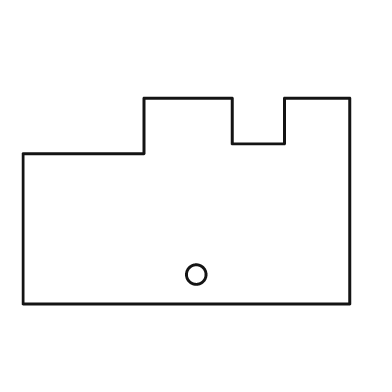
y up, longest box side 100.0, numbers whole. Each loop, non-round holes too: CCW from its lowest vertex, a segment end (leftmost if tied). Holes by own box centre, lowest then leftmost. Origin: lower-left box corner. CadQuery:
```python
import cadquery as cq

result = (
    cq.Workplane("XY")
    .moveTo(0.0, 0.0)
    .lineTo(100.0, 0.0)
    .lineTo(100.0, 63.0)
    .lineTo(80.0, 63.0)
    .lineTo(80.0, 49.0)
    .lineTo(64.0, 49.0)
    .lineTo(64.0, 63.0)
    .lineTo(37.0, 63.0)
    .lineTo(37.0, 46.0)
    .lineTo(0.0, 46.0)
    .close()
    .moveTo(53.0, 9.0)
    .circle(3.0)
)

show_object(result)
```